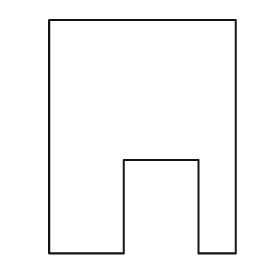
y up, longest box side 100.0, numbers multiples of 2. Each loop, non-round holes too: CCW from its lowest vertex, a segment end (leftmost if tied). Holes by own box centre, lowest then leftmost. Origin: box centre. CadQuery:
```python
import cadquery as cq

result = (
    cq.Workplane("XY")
    .moveTo(-40.0, -50.0)
    .lineTo(-8.0, -50.0)
    .lineTo(-8.0, -10.0)
    .lineTo(24.0, -10.0)
    .lineTo(24.0, -50.0)
    .lineTo(40.0, -50.0)
    .lineTo(40.0, 50.0)
    .lineTo(-40.0, 50.0)
    .close()
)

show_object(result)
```